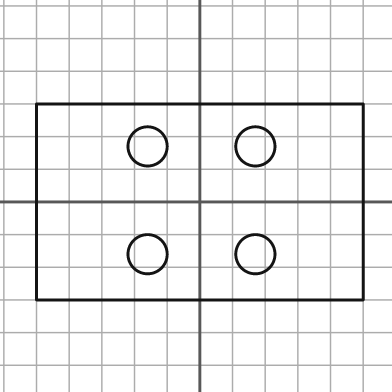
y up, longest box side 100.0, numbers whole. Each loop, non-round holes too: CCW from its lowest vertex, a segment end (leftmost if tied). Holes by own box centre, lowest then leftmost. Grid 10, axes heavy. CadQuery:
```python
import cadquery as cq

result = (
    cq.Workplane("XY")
    .moveTo(-50.0, -30.0)
    .lineTo(50.0, -30.0)
    .lineTo(50.0, 30.0)
    .lineTo(-50.0, 30.0)
    .close()
    .moveTo(-16.0, -16.0)
    .circle(6.0)
    .moveTo(17.0, -16.0)
    .circle(6.0)
    .moveTo(-16.0, 17.0)
    .circle(6.0)
    .moveTo(17.0, 17.0)
    .circle(6.0)
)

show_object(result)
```